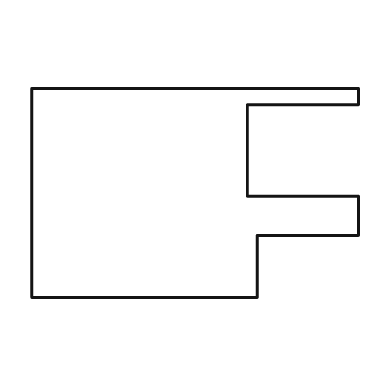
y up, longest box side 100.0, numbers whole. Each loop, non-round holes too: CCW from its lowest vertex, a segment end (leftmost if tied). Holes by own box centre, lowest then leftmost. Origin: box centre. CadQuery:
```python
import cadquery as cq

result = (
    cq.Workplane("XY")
    .moveTo(-50.0, -32.0)
    .lineTo(19.0, -32.0)
    .lineTo(19.0, -13.0)
    .lineTo(50.0, -13.0)
    .lineTo(50.0, -1.0)
    .lineTo(16.0, -1.0)
    .lineTo(16.0, 27.0)
    .lineTo(50.0, 27.0)
    .lineTo(50.0, 32.0)
    .lineTo(-50.0, 32.0)
    .close()
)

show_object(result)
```